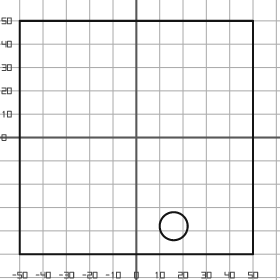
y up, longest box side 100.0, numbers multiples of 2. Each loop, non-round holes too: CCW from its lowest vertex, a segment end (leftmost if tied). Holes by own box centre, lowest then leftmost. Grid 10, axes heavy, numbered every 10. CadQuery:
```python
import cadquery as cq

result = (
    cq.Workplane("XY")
    .moveTo(-50.0, -50.0)
    .lineTo(50.0, -50.0)
    .lineTo(50.0, 50.0)
    .lineTo(-50.0, 50.0)
    .close()
    .moveTo(16.0, -38.0)
    .circle(6.0)
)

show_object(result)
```